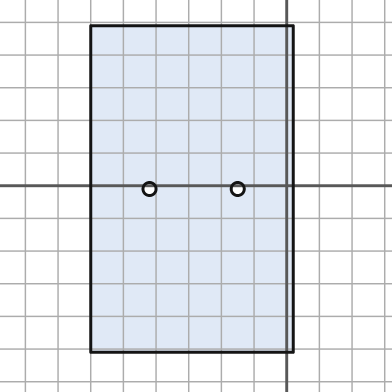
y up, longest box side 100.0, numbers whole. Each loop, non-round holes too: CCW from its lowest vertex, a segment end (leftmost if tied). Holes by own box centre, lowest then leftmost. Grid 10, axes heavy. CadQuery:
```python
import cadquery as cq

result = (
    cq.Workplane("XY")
    .moveTo(-60.0, -51.0)
    .lineTo(2.0, -51.0)
    .lineTo(2.0, 49.0)
    .lineTo(-60.0, 49.0)
    .close()
    .moveTo(-42.0, -1.0)
    .circle(2.0)
    .moveTo(-15.0, -1.0)
    .circle(2.0)
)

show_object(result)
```